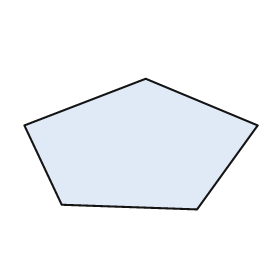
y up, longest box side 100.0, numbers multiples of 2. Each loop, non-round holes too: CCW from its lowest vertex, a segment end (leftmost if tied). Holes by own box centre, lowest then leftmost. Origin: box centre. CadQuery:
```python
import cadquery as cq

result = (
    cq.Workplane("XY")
    .moveTo(24.0, -28.0)
    .lineTo(50.0, 8.0)
    .lineTo(2.0, 28.0)
    .lineTo(-50.0, 8.0)
    .lineTo(-34.0, -26.0)
    .close()
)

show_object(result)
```